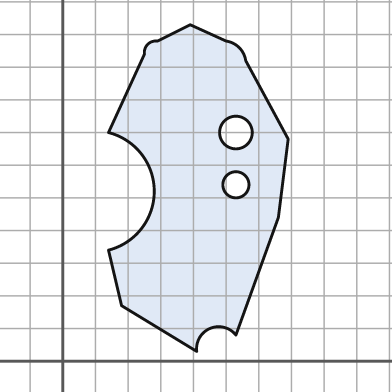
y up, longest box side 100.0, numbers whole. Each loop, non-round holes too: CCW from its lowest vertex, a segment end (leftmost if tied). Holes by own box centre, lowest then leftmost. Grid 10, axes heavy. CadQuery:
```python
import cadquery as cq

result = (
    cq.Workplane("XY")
    .moveTo(41.0, 3.0)
    .threePointArc((45.0, 10.0), (53.0, 8.0))
    .lineTo(66.0, 44.0)
    .lineTo(69.0, 68.0)
    .lineTo(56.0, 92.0)
    .threePointArc((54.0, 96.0), (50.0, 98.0))
    .lineTo(39.0, 103.0)
    .lineTo(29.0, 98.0)
    .threePointArc((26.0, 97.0), (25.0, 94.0))
    .lineTo(14.0, 70.0)
    .threePointArc((28.0, 52.0), (14.0, 34.0))
    .lineTo(18.0, 17.0)
    .close()
    .moveTo(53.0, 54.0)
    .circle(4.0)
    .moveTo(53.0, 70.0)
    .circle(5.0)
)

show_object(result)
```